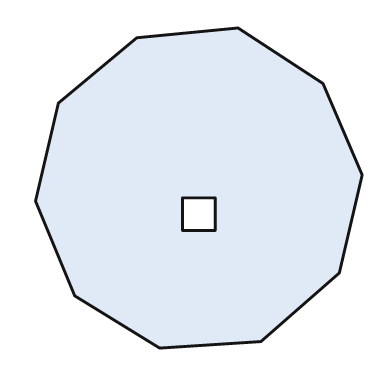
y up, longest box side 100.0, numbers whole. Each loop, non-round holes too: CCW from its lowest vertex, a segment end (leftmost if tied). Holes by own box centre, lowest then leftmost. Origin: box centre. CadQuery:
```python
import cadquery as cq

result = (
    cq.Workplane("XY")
    .moveTo(-12.0, -49.0)
    .lineTo(19.0, -47.0)
    .lineTo(43.0, -26.0)
    .lineTo(50.0, 4.0)
    .lineTo(38.0, 32.0)
    .lineTo(12.0, 49.0)
    .lineTo(-19.0, 46.0)
    .lineTo(-43.0, 26.0)
    .lineTo(-50.0, -4.0)
    .lineTo(-38.0, -33.0)
    .close()
    .moveTo(-5.0, -13.0)
    .lineTo(5.0, -13.0)
    .lineTo(5.0, -3.0)
    .lineTo(-5.0, -3.0)
    .close()
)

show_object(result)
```